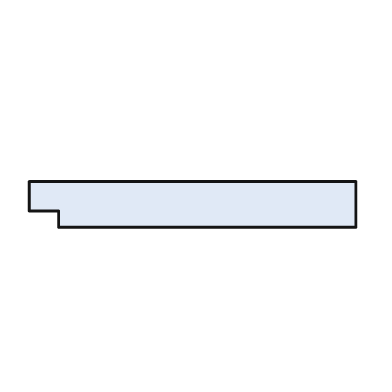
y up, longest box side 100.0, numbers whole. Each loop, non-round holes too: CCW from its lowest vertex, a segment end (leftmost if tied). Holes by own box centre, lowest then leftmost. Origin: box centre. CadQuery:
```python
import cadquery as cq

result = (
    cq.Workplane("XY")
    .moveTo(-41.0, -7.0)
    .lineTo(50.0, -7.0)
    .lineTo(50.0, 7.0)
    .lineTo(-50.0, 7.0)
    .lineTo(-50.0, -2.0)
    .lineTo(-41.0, -2.0)
    .close()
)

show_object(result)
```